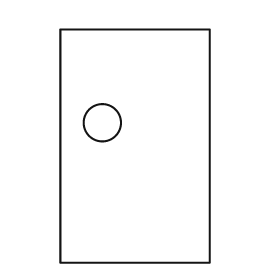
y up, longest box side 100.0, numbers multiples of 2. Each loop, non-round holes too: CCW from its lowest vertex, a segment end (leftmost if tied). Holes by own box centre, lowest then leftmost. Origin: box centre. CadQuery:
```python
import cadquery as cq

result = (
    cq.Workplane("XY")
    .moveTo(-32.0, -50.0)
    .lineTo(32.0, -50.0)
    .lineTo(32.0, 50.0)
    .lineTo(-32.0, 50.0)
    .close()
    .moveTo(-14.0, 10.0)
    .circle(8.0)
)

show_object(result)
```